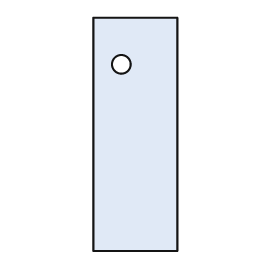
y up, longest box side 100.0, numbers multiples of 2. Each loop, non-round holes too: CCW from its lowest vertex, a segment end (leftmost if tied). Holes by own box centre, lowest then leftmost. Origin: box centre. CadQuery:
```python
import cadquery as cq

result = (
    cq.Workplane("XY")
    .moveTo(-18.0, -50.0)
    .lineTo(18.0, -50.0)
    .lineTo(18.0, 50.0)
    .lineTo(-18.0, 50.0)
    .close()
    .moveTo(-6.0, 30.0)
    .circle(4.0)
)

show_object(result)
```